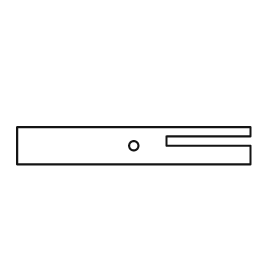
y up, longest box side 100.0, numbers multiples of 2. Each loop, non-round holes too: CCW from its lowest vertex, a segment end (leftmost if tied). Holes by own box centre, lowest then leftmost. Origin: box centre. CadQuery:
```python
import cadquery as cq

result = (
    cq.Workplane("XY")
    .moveTo(-50.0, -8.0)
    .lineTo(50.0, -8.0)
    .lineTo(50.0, 0.0)
    .lineTo(14.0, 0.0)
    .lineTo(14.0, 4.0)
    .lineTo(50.0, 4.0)
    .lineTo(50.0, 8.0)
    .lineTo(-50.0, 8.0)
    .close()
    .moveTo(0.0, 0.0)
    .circle(2.0)
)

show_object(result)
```